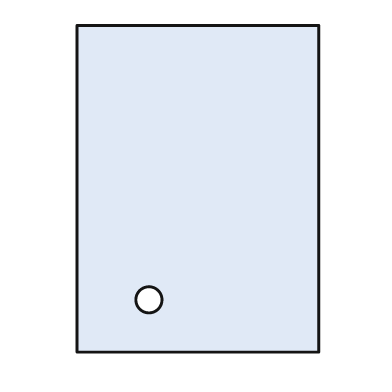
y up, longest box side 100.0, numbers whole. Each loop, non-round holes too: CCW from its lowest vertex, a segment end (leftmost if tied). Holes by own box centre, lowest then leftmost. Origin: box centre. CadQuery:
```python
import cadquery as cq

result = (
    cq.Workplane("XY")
    .moveTo(-37.0, -50.0)
    .lineTo(37.0, -50.0)
    .lineTo(37.0, 50.0)
    .lineTo(-37.0, 50.0)
    .close()
    .moveTo(-15.0, -34.0)
    .circle(4.0)
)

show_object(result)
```